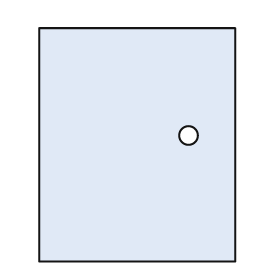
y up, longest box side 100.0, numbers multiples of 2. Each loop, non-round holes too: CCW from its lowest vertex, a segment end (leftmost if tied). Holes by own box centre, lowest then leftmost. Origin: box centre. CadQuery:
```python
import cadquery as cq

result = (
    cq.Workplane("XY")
    .moveTo(-42.0, -50.0)
    .lineTo(42.0, -50.0)
    .lineTo(42.0, 50.0)
    .lineTo(-42.0, 50.0)
    .close()
    .moveTo(22.0, 4.0)
    .circle(4.0)
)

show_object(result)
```